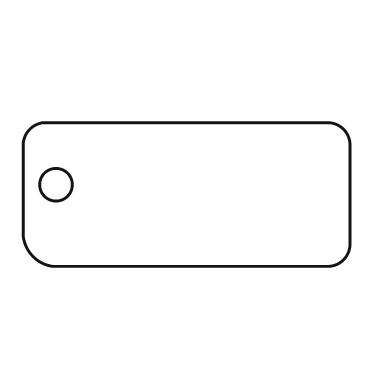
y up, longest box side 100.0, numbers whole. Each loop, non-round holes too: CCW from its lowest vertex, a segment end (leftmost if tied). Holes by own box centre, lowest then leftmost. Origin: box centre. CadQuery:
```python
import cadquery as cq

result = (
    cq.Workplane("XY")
    .moveTo(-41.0, -22.0)
    .lineTo(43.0, -22.0)
    .threePointArc((48.0, -20.0), (50.0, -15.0))
    .lineTo(50.0, 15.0)
    .threePointArc((48.0, 20.0), (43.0, 22.0))
    .lineTo(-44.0, 22.0)
    .threePointArc((-48.0, 20.0), (-50.0, 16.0))
    .lineTo(-50.0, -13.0)
    .threePointArc((-47.0, -19.0), (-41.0, -22.0))
    .close()
    .moveTo(-40.0, 3.0)
    .circle(5.0)
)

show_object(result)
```